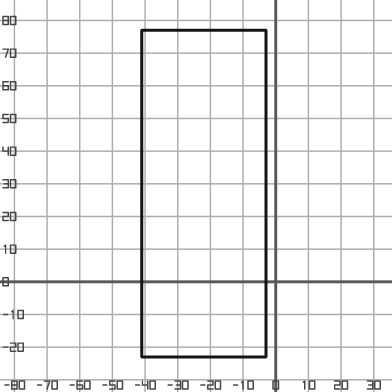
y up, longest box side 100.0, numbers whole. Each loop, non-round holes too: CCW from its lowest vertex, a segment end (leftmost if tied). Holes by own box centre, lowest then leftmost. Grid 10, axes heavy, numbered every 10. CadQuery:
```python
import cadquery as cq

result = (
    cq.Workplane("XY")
    .moveTo(-41.0, -23.0)
    .lineTo(-3.0, -23.0)
    .lineTo(-3.0, 77.0)
    .lineTo(-41.0, 77.0)
    .close()
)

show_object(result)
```